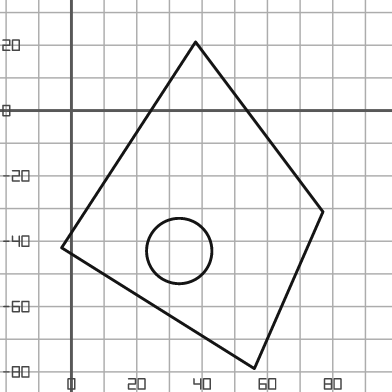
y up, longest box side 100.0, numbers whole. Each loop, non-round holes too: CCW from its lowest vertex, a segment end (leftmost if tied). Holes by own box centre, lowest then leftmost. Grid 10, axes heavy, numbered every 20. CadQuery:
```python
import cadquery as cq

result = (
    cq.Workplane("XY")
    .moveTo(56.0, -79.0)
    .lineTo(77.0, -31.0)
    .lineTo(38.0, 21.0)
    .lineTo(-3.0, -42.0)
    .close()
    .moveTo(33.0, -43.0)
    .circle(10.0)
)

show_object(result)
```